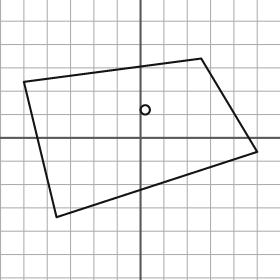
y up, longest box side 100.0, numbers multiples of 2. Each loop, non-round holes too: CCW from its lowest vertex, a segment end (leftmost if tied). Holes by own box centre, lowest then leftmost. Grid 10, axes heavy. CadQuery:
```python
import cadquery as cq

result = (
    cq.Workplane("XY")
    .moveTo(-36.0, -34.0)
    .lineTo(50.0, -6.0)
    .lineTo(26.0, 34.0)
    .lineTo(-50.0, 24.0)
    .close()
    .moveTo(2.0, 12.0)
    .circle(2.0)
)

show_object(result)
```